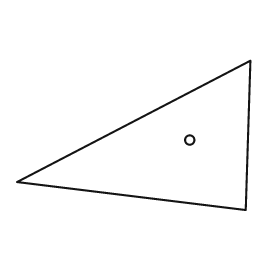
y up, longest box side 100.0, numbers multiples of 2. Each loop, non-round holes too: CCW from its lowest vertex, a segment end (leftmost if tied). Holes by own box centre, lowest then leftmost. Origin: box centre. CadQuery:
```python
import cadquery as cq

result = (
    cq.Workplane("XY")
    .moveTo(48.0, -32.0)
    .lineTo(50.0, 32.0)
    .lineTo(-50.0, -20.0)
    .close()
    .moveTo(24.0, -2.0)
    .circle(2.0)
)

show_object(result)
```